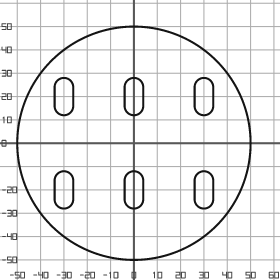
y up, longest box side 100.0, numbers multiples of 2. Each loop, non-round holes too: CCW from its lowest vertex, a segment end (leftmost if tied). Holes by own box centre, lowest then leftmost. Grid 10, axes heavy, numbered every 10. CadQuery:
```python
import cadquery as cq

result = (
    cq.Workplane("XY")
    .moveTo(0.0, 0.0)
    .circle(50.0)
    .moveTo(-34.0, -24.0)
    .threePointArc((-30.0, -28.0), (-26.0, -24.0))
    .lineTo(-26.0, -16.0)
    .threePointArc((-30.0, -12.0), (-34.0, -16.0))
    .close()
    .moveTo(-4.0, -24.0)
    .threePointArc((0.0, -28.0), (4.0, -24.0))
    .lineTo(4.0, -16.0)
    .threePointArc((0.0, -12.0), (-4.0, -16.0))
    .close()
    .moveTo(26.0, -24.0)
    .threePointArc((30.0, -28.0), (34.0, -24.0))
    .lineTo(34.0, -16.0)
    .threePointArc((30.0, -12.0), (26.0, -16.0))
    .close()
    .moveTo(-34.0, 16.0)
    .threePointArc((-30.0, 12.0), (-26.0, 16.0))
    .lineTo(-26.0, 24.0)
    .threePointArc((-30.0, 28.0), (-34.0, 24.0))
    .close()
    .moveTo(-4.0, 16.0)
    .threePointArc((0.0, 12.0), (4.0, 16.0))
    .lineTo(4.0, 24.0)
    .threePointArc((0.0, 28.0), (-4.0, 24.0))
    .close()
    .moveTo(26.0, 16.0)
    .threePointArc((30.0, 12.0), (34.0, 16.0))
    .lineTo(34.0, 24.0)
    .threePointArc((30.0, 28.0), (26.0, 24.0))
    .close()
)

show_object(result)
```